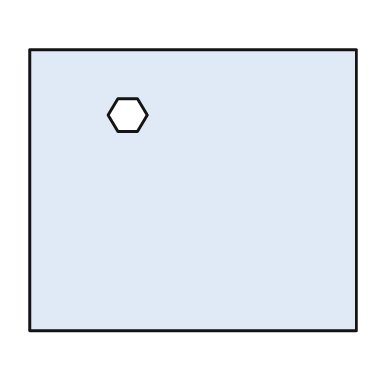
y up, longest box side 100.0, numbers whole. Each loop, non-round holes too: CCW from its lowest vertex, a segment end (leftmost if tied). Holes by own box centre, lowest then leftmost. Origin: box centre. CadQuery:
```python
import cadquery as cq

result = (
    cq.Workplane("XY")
    .moveTo(-50.0, -43.0)
    .lineTo(50.0, -43.0)
    .lineTo(50.0, 43.0)
    .lineTo(-50.0, 43.0)
    .close()
    .moveTo(-23.0, 18.0)
    .lineTo(-17.0, 18.0)
    .lineTo(-14.0, 23.0)
    .lineTo(-17.0, 28.0)
    .lineTo(-23.0, 28.0)
    .lineTo(-26.0, 23.0)
    .close()
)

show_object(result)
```